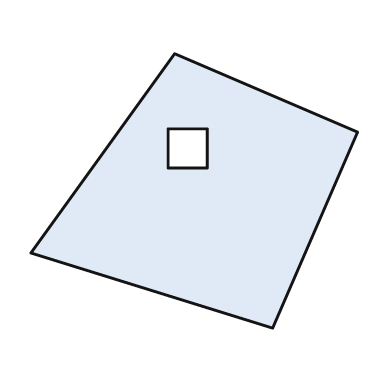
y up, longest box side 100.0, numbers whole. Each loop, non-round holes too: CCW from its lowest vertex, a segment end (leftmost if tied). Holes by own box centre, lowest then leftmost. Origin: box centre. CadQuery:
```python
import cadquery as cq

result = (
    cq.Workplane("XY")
    .moveTo(24.0, -42.0)
    .lineTo(50.0, 18.0)
    .lineTo(-6.0, 42.0)
    .lineTo(-50.0, -19.0)
    .close()
    .moveTo(-8.0, 7.0)
    .lineTo(4.0, 7.0)
    .lineTo(4.0, 19.0)
    .lineTo(-8.0, 19.0)
    .close()
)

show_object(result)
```